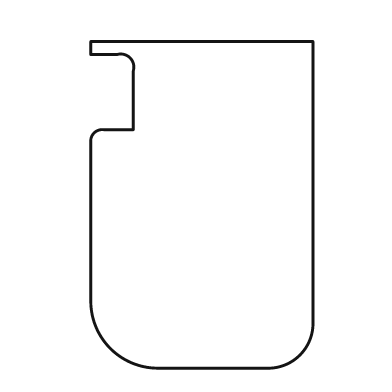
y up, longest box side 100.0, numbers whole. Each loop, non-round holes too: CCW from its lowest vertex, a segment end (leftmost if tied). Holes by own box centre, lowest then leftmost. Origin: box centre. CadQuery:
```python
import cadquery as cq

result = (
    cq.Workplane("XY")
    .moveTo(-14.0, -50.0)
    .lineTo(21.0, -50.0)
    .threePointArc((30.0, -46.0), (34.0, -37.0))
    .lineTo(34.0, 50.0)
    .lineTo(-34.0, 50.0)
    .lineTo(-34.0, 46.0)
    .lineTo(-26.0, 46.0)
    .threePointArc((-22.0, 45.0), (-21.0, 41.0))
    .lineTo(-21.0, 23.0)
    .lineTo(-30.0, 23.0)
    .threePointArc((-33.0, 22.0), (-34.0, 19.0))
    .lineTo(-34.0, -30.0)
    .threePointArc((-28.0, -44.0), (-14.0, -50.0))
    .close()
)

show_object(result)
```